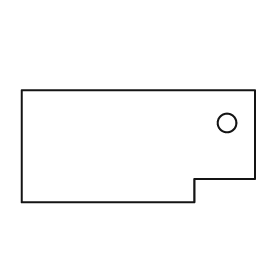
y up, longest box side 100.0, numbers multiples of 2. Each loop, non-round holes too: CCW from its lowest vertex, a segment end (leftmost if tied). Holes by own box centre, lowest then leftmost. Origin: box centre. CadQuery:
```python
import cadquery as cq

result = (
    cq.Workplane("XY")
    .moveTo(-50.0, -24.0)
    .lineTo(24.0, -24.0)
    .lineTo(24.0, -14.0)
    .lineTo(50.0, -14.0)
    .lineTo(50.0, 24.0)
    .lineTo(-50.0, 24.0)
    .close()
    .moveTo(38.0, 10.0)
    .circle(4.0)
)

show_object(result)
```